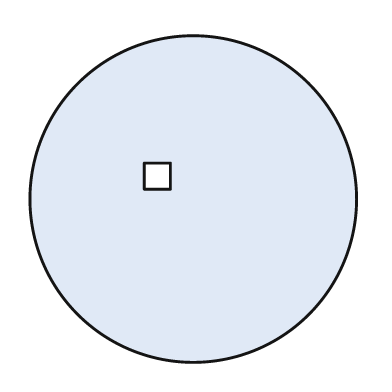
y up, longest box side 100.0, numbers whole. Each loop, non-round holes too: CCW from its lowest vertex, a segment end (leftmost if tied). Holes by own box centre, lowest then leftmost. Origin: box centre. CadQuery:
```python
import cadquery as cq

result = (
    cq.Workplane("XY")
    .moveTo(0.0, 0.0)
    .circle(50.0)
    .moveTo(-15.0, 3.0)
    .lineTo(-7.0, 3.0)
    .lineTo(-7.0, 11.0)
    .lineTo(-15.0, 11.0)
    .close()
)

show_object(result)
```